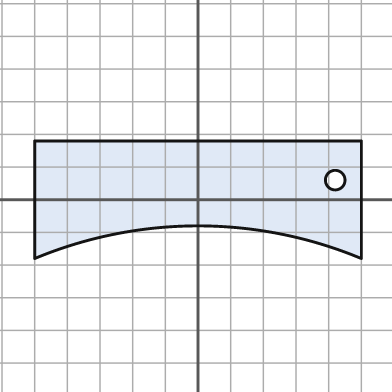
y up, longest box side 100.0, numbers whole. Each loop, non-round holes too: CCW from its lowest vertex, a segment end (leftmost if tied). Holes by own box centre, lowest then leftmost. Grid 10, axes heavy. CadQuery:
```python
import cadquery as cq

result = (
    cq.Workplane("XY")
    .moveTo(-50.0, -18.0)
    .threePointArc((0.0, -8.0), (50.0, -18.0))
    .lineTo(50.0, 18.0)
    .lineTo(-50.0, 18.0)
    .close()
    .moveTo(42.0, 6.0)
    .circle(3.0)
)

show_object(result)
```